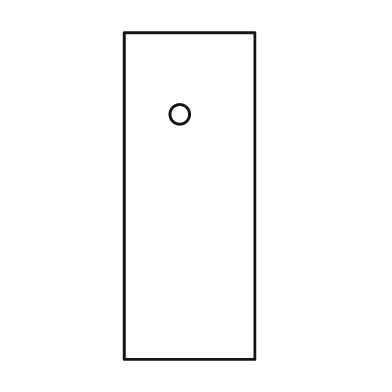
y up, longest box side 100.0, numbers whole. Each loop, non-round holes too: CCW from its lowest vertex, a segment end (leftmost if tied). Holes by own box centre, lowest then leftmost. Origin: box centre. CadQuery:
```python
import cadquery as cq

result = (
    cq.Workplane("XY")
    .moveTo(-20.0, -50.0)
    .lineTo(20.0, -50.0)
    .lineTo(20.0, 50.0)
    .lineTo(-20.0, 50.0)
    .close()
    .moveTo(-3.0, 25.0)
    .circle(3.0)
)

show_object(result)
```